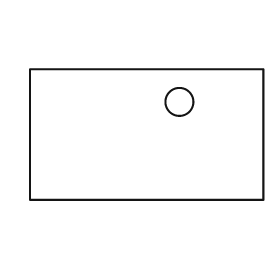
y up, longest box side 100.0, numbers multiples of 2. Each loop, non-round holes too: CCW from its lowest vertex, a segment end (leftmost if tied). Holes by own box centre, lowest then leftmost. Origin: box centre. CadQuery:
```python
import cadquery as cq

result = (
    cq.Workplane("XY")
    .moveTo(-50.0, -28.0)
    .lineTo(50.0, -28.0)
    .lineTo(50.0, 28.0)
    .lineTo(-50.0, 28.0)
    .close()
    .moveTo(14.0, 14.0)
    .circle(6.0)
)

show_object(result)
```